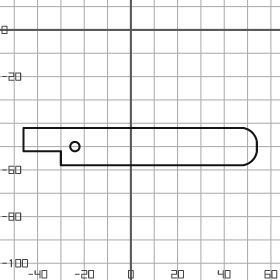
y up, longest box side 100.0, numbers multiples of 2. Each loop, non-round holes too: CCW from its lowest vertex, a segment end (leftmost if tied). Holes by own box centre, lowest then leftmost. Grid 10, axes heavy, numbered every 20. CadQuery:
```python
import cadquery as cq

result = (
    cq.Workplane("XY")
    .moveTo(-30.0, -58.0)
    .lineTo(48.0, -58.0)
    .threePointArc((52.0, -56.0), (54.0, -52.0))
    .lineTo(54.0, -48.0)
    .threePointArc((52.0, -44.0), (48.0, -42.0))
    .lineTo(-46.0, -42.0)
    .lineTo(-46.0, -52.0)
    .lineTo(-30.0, -52.0)
    .close()
    .moveTo(-24.0, -50.0)
    .circle(2.0)
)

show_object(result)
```